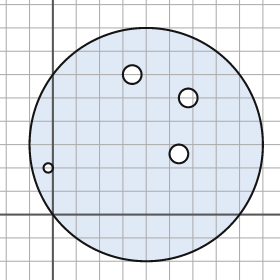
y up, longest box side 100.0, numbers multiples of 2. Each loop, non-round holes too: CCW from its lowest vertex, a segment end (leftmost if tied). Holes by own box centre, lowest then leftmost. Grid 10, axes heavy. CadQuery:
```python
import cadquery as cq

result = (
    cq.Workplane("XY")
    .moveTo(40.0, 30.0)
    .circle(50.0)
    .moveTo(-2.0, 20.0)
    .circle(2.0)
    .moveTo(54.0, 26.0)
    .circle(4.0)
    .moveTo(58.0, 50.0)
    .circle(4.0)
    .moveTo(34.0, 60.0)
    .circle(4.0)
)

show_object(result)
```